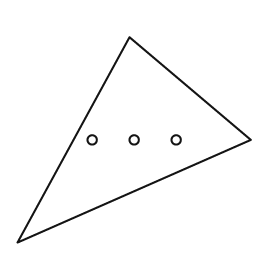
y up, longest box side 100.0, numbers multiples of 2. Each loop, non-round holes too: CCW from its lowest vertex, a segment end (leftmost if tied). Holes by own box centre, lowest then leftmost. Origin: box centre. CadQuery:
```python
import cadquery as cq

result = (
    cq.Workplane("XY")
    .moveTo(-50.0, -44.0)
    .lineTo(50.0, 0.0)
    .lineTo(-2.0, 44.0)
    .close()
    .moveTo(-18.0, 0.0)
    .circle(2.0)
    .moveTo(0.0, 0.0)
    .circle(2.0)
    .moveTo(18.0, 0.0)
    .circle(2.0)
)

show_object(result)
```